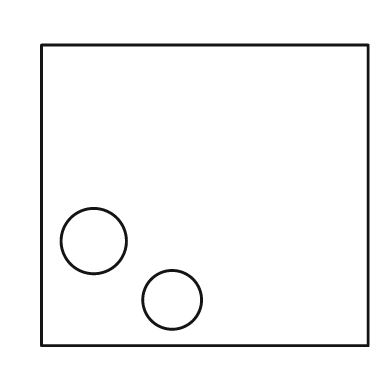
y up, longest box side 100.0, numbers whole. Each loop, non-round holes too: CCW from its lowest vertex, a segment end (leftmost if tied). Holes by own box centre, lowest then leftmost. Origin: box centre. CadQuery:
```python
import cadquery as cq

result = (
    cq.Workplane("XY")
    .moveTo(-50.0, -46.0)
    .lineTo(50.0, -46.0)
    .lineTo(50.0, 46.0)
    .lineTo(-50.0, 46.0)
    .close()
    .moveTo(-10.0, -32.0)
    .circle(9.0)
    .moveTo(-34.0, -14.0)
    .circle(10.0)
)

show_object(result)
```